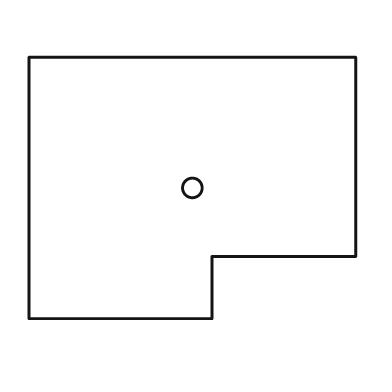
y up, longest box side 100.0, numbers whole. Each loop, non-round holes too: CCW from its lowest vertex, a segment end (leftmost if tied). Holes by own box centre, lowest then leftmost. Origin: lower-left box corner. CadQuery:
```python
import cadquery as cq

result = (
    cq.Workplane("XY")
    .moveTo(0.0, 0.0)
    .lineTo(56.0, 0.0)
    .lineTo(56.0, 19.0)
    .lineTo(100.0, 19.0)
    .lineTo(100.0, 80.0)
    .lineTo(0.0, 80.0)
    .close()
    .moveTo(50.0, 40.0)
    .circle(3.0)
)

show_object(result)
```